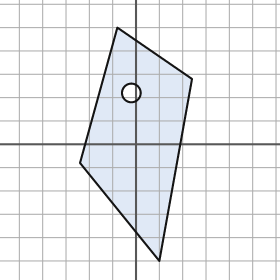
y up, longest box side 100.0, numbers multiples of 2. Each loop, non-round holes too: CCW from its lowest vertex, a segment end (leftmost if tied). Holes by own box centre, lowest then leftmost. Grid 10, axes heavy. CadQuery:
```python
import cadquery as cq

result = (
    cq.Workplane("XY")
    .moveTo(10.0, -50.0)
    .lineTo(24.0, 28.0)
    .lineTo(-8.0, 50.0)
    .lineTo(-24.0, -8.0)
    .close()
    .moveTo(-2.0, 22.0)
    .circle(4.0)
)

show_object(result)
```